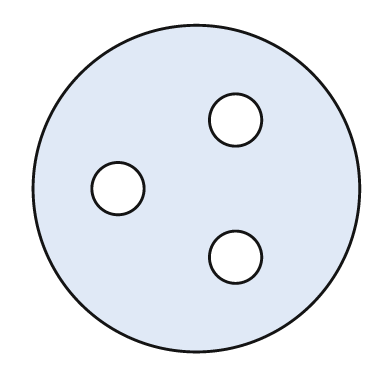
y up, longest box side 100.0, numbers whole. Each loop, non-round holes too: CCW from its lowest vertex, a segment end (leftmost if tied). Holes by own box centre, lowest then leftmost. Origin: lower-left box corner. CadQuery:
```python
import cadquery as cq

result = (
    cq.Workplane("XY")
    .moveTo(50.0, 50.0)
    .circle(50.0)
    .moveTo(62.0, 29.0)
    .circle(8.0)
    .moveTo(26.0, 50.0)
    .circle(8.0)
    .moveTo(62.0, 71.0)
    .circle(8.0)
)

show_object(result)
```